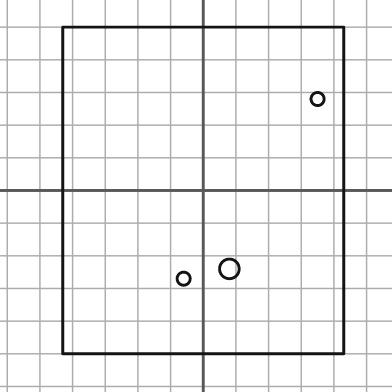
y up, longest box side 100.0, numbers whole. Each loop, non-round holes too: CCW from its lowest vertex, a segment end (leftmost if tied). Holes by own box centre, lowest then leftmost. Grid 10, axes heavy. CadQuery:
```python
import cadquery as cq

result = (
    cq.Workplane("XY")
    .moveTo(-43.0, -50.0)
    .lineTo(43.0, -50.0)
    .lineTo(43.0, 50.0)
    .lineTo(-43.0, 50.0)
    .close()
    .moveTo(-6.0, -27.0)
    .circle(2.0)
    .moveTo(8.0, -24.0)
    .circle(3.0)
    .moveTo(35.0, 28.0)
    .circle(2.0)
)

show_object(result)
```